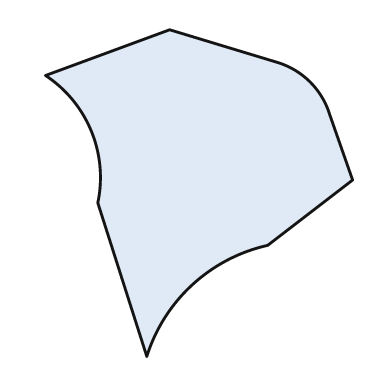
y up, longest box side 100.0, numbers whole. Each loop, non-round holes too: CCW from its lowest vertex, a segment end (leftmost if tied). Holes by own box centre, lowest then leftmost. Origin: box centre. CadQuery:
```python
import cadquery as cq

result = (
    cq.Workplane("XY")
    .moveTo(-16.0, -50.0)
    .threePointArc((-2.0, -28.0), (21.0, -16.0))
    .lineTo(47.0, 4.0)
    .lineTo(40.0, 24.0)
    .threePointArc((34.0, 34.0), (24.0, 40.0))
    .lineTo(-9.0, 50.0)
    .lineTo(-47.0, 36.0)
    .threePointArc((-33.0, 19.0), (-31.0, -3.0))
    .close()
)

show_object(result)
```